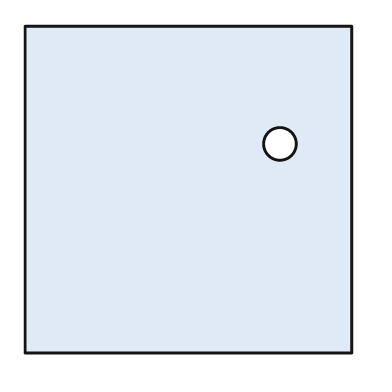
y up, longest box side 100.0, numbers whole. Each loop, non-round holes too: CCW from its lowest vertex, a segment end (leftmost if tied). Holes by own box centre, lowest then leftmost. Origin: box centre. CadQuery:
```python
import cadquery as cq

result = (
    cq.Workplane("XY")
    .moveTo(-50.0, -50.0)
    .lineTo(50.0, -50.0)
    .lineTo(50.0, 50.0)
    .lineTo(-50.0, 50.0)
    .close()
    .moveTo(28.0, 14.0)
    .circle(5.0)
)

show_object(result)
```